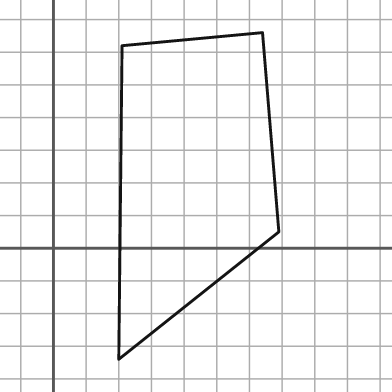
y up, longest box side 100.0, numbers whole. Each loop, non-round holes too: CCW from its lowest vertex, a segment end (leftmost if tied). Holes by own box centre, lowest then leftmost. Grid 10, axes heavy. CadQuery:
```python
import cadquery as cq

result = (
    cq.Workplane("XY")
    .moveTo(20.0, -34.0)
    .lineTo(69.0, 5.0)
    .lineTo(64.0, 66.0)
    .lineTo(21.0, 62.0)
    .close()
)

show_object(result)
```